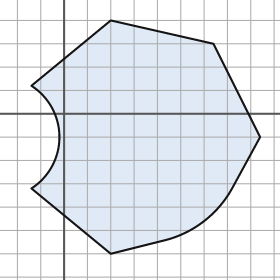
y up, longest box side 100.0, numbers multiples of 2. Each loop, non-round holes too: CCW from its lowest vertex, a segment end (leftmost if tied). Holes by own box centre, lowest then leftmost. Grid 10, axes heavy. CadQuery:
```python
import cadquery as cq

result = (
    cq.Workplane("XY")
    .moveTo(20.0, -60.0)
    .lineTo(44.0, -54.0)
    .threePointArc((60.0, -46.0), (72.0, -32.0))
    .lineTo(84.0, -10.0)
    .lineTo(64.0, 30.0)
    .lineTo(20.0, 40.0)
    .lineTo(-14.0, 12.0)
    .threePointArc((-2.0, -10.0), (-14.0, -32.0))
    .close()
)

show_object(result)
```